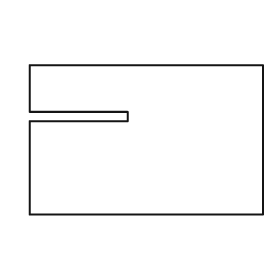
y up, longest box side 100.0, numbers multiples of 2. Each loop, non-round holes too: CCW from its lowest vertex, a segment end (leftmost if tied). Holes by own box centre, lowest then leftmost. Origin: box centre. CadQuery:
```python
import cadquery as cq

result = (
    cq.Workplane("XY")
    .moveTo(-50.0, -32.0)
    .lineTo(50.0, -32.0)
    .lineTo(50.0, 32.0)
    .lineTo(-50.0, 32.0)
    .lineTo(-50.0, 12.0)
    .lineTo(-8.0, 12.0)
    .lineTo(-8.0, 8.0)
    .lineTo(-50.0, 8.0)
    .close()
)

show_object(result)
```